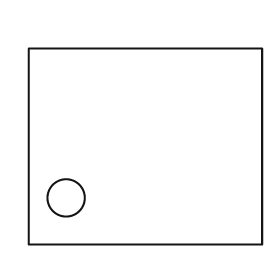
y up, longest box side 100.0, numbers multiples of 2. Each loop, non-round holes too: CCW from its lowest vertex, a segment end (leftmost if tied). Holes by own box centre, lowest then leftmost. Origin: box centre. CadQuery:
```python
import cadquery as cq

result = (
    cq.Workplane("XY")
    .moveTo(-50.0, -42.0)
    .lineTo(50.0, -42.0)
    .lineTo(50.0, 42.0)
    .lineTo(-50.0, 42.0)
    .close()
    .moveTo(-34.0, -22.0)
    .circle(8.0)
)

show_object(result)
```